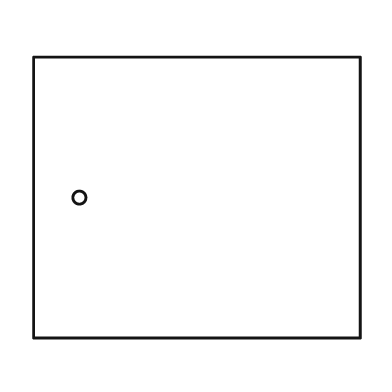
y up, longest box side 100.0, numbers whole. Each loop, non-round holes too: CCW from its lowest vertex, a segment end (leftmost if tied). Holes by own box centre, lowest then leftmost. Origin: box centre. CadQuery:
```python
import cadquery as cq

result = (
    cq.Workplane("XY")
    .moveTo(-50.0, -43.0)
    .lineTo(50.0, -43.0)
    .lineTo(50.0, 43.0)
    .lineTo(-50.0, 43.0)
    .close()
    .moveTo(-36.0, 0.0)
    .circle(2.0)
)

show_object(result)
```